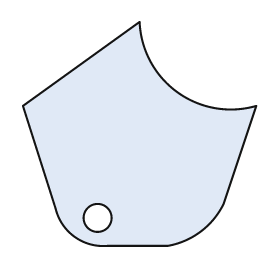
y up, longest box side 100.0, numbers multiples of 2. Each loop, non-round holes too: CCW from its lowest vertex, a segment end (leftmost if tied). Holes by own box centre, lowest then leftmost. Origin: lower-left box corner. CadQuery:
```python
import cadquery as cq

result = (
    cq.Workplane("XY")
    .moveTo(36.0, 0.0)
    .lineTo(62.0, 0.0)
    .threePointArc((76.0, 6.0), (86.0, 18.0))
    .lineTo(100.0, 60.0)
    .threePointArc((66.0, 66.0), (50.0, 96.0))
    .lineTo(0.0, 60.0)
    .lineTo(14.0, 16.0)
    .threePointArc((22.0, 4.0), (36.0, 0.0))
    .close()
    .moveTo(32.0, 12.0)
    .circle(6.0)
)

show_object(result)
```